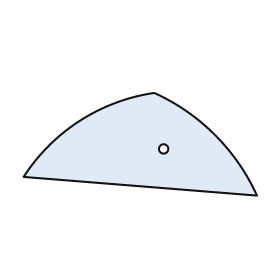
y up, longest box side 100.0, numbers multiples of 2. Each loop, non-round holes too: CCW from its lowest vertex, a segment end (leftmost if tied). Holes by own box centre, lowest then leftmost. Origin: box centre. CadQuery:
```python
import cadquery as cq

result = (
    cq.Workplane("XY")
    .moveTo(50.0, -22.0)
    .threePointArc((32.0, 4.0), (6.0, 22.0))
    .threePointArc((-26.0, 10.0), (-50.0, -14.0))
    .close()
    .moveTo(10.0, -2.0)
    .circle(2.0)
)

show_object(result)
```